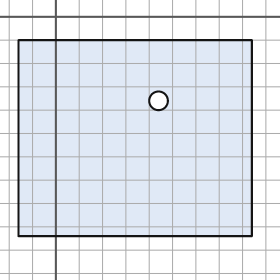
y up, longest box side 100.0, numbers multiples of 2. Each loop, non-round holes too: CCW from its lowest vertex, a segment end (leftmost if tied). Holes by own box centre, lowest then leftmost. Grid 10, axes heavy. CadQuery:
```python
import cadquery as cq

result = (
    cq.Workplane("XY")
    .moveTo(-16.0, -94.0)
    .lineTo(84.0, -94.0)
    .lineTo(84.0, -10.0)
    .lineTo(-16.0, -10.0)
    .close()
    .moveTo(44.0, -36.0)
    .circle(4.0)
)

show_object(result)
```